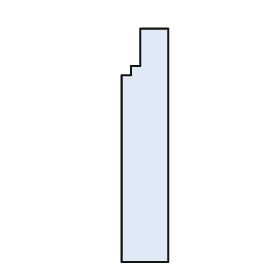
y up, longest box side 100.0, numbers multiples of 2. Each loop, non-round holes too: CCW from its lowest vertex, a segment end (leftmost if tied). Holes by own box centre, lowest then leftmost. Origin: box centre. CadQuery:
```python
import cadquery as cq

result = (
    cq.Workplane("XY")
    .moveTo(-10.0, -50.0)
    .lineTo(10.0, -50.0)
    .lineTo(10.0, 50.0)
    .lineTo(-2.0, 50.0)
    .lineTo(-2.0, 34.0)
    .lineTo(-6.0, 34.0)
    .lineTo(-6.0, 30.0)
    .lineTo(-10.0, 30.0)
    .close()
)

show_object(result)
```